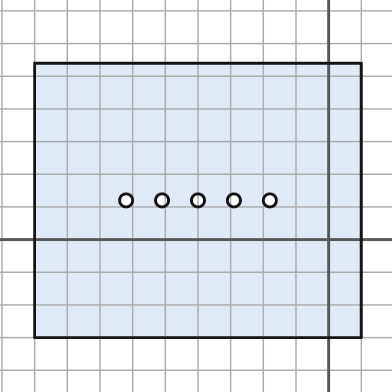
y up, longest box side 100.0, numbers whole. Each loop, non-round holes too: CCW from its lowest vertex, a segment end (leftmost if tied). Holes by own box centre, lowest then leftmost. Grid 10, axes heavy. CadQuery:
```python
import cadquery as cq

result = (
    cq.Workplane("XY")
    .moveTo(-90.0, -30.0)
    .lineTo(10.0, -30.0)
    .lineTo(10.0, 54.0)
    .lineTo(-90.0, 54.0)
    .close()
    .moveTo(-62.0, 12.0)
    .circle(2.0)
    .moveTo(-51.0, 12.0)
    .circle(2.0)
    .moveTo(-40.0, 12.0)
    .circle(2.0)
    .moveTo(-29.0, 12.0)
    .circle(2.0)
    .moveTo(-18.0, 12.0)
    .circle(2.0)
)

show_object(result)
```